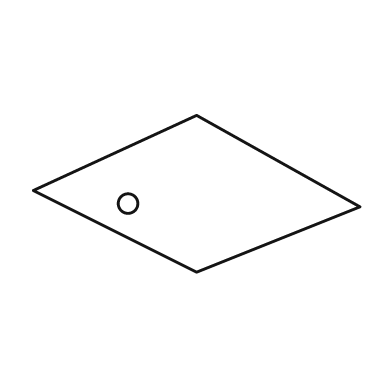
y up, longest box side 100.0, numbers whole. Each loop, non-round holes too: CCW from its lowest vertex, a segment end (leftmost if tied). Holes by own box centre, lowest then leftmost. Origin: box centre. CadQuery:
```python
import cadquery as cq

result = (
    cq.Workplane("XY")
    .moveTo(0.0, -24.0)
    .lineTo(50.0, -4.0)
    .lineTo(0.0, 24.0)
    .lineTo(-50.0, 1.0)
    .close()
    .moveTo(-21.0, -3.0)
    .circle(3.0)
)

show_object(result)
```